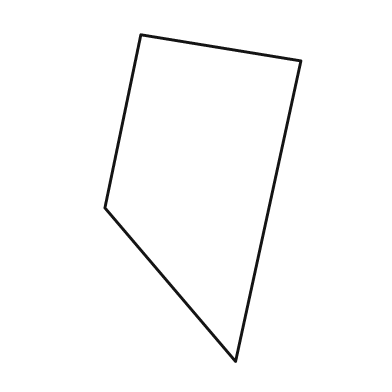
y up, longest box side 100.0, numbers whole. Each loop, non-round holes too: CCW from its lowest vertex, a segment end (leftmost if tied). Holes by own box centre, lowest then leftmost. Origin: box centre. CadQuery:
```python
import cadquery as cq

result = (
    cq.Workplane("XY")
    .moveTo(10.0, -50.0)
    .lineTo(30.0, 42.0)
    .lineTo(-19.0, 50.0)
    .lineTo(-30.0, -3.0)
    .close()
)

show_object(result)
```